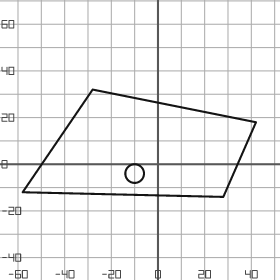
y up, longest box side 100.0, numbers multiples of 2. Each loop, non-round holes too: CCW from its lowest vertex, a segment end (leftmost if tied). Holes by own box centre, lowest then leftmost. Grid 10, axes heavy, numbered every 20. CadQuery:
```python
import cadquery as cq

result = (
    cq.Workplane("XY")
    .moveTo(28.0, -14.0)
    .lineTo(42.0, 18.0)
    .lineTo(-28.0, 32.0)
    .lineTo(-58.0, -12.0)
    .close()
    .moveTo(-10.0, -4.0)
    .circle(4.0)
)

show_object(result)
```